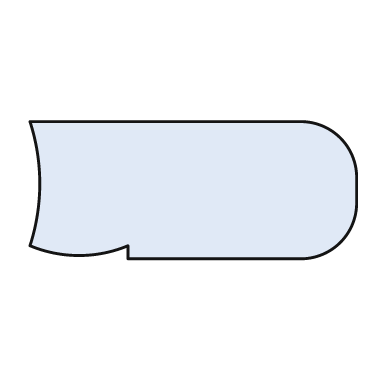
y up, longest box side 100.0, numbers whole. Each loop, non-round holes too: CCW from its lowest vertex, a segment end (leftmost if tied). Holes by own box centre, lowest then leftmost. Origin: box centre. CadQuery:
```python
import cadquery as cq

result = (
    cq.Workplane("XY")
    .moveTo(-20.0, -21.0)
    .lineTo(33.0, -21.0)
    .threePointArc((45.0, -16.0), (50.0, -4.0))
    .lineTo(50.0, 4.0)
    .threePointArc((45.0, 16.0), (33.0, 21.0))
    .lineTo(-50.0, 21.0)
    .threePointArc((-47.0, 2.0), (-50.0, -17.0))
    .threePointArc((-35.0, -20.0), (-20.0, -17.0))
    .close()
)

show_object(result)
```